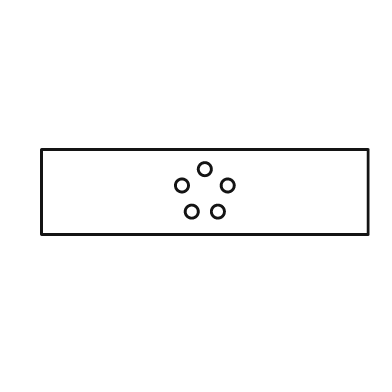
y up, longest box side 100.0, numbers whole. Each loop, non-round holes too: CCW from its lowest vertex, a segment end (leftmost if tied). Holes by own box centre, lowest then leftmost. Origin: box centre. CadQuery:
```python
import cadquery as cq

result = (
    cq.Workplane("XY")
    .moveTo(-50.0, -13.0)
    .lineTo(50.0, -13.0)
    .lineTo(50.0, 13.0)
    .lineTo(-50.0, 13.0)
    .close()
    .moveTo(-4.0, -6.0)
    .circle(2.0)
    .moveTo(4.0, -6.0)
    .circle(2.0)
    .moveTo(-7.0, 2.0)
    .circle(2.0)
    .moveTo(7.0, 2.0)
    .circle(2.0)
    .moveTo(0.0, 7.0)
    .circle(2.0)
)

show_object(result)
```